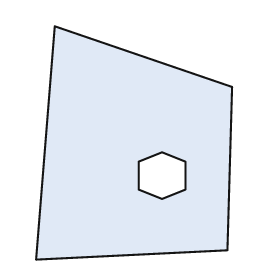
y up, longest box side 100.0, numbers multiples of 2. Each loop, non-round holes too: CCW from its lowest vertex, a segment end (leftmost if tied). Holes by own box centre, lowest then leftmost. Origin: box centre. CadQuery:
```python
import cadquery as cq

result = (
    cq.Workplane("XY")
    .moveTo(-42.0, -50.0)
    .lineTo(40.0, -46.0)
    .lineTo(42.0, 24.0)
    .lineTo(-34.0, 50.0)
    .close()
    .moveTo(12.0, -24.0)
    .lineTo(22.0, -20.0)
    .lineTo(22.0, -8.0)
    .lineTo(12.0, -4.0)
    .lineTo(2.0, -8.0)
    .lineTo(2.0, -20.0)
    .close()
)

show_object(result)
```